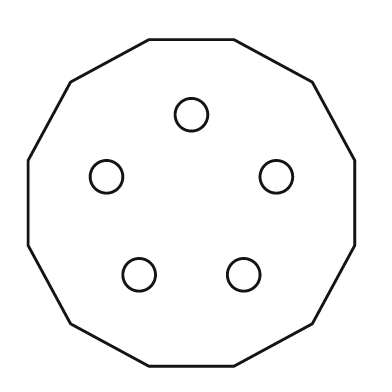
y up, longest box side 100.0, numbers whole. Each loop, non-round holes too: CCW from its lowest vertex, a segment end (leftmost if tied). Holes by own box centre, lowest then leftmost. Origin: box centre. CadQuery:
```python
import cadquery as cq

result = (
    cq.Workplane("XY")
    .moveTo(-13.0, -50.0)
    .lineTo(13.0, -50.0)
    .lineTo(37.0, -37.0)
    .lineTo(50.0, -13.0)
    .lineTo(50.0, 13.0)
    .lineTo(37.0, 37.0)
    .lineTo(13.0, 50.0)
    .lineTo(-13.0, 50.0)
    .lineTo(-37.0, 37.0)
    .lineTo(-50.0, 13.0)
    .lineTo(-50.0, -13.0)
    .lineTo(-37.0, -37.0)
    .close()
    .moveTo(-16.0, -22.0)
    .circle(5.0)
    .moveTo(16.0, -22.0)
    .circle(5.0)
    .moveTo(-26.0, 8.0)
    .circle(5.0)
    .moveTo(26.0, 8.0)
    .circle(5.0)
    .moveTo(0.0, 27.0)
    .circle(5.0)
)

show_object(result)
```